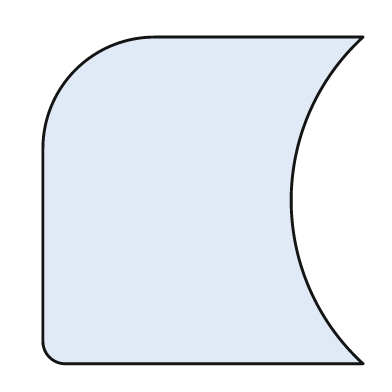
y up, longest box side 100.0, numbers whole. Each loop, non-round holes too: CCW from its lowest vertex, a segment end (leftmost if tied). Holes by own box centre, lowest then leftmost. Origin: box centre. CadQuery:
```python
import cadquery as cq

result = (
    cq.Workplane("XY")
    .moveTo(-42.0, -50.0)
    .lineTo(49.0, -50.0)
    .threePointArc((27.0, 0.0), (49.0, 50.0))
    .lineTo(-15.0, 50.0)
    .threePointArc((-39.0, 40.0), (-49.0, 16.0))
    .lineTo(-49.0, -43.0)
    .threePointArc((-47.0, -48.0), (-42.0, -50.0))
    .close()
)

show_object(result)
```